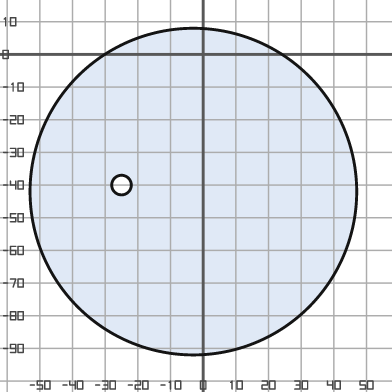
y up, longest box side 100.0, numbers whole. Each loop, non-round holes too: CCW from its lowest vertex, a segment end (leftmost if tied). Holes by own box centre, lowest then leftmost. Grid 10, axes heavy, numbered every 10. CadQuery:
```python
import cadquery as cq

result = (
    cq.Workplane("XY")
    .moveTo(-3.0, -42.0)
    .circle(50.0)
    .moveTo(-25.0, -40.0)
    .circle(3.0)
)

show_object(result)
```